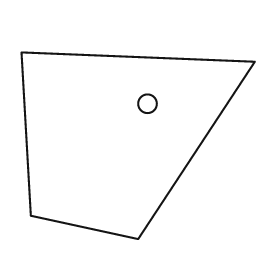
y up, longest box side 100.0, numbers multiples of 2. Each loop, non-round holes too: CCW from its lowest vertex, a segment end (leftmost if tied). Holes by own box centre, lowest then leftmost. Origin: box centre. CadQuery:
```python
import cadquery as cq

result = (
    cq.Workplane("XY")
    .moveTo(0.0, -40.0)
    .lineTo(50.0, 36.0)
    .lineTo(-50.0, 40.0)
    .lineTo(-46.0, -30.0)
    .close()
    .moveTo(4.0, 18.0)
    .circle(4.0)
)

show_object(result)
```